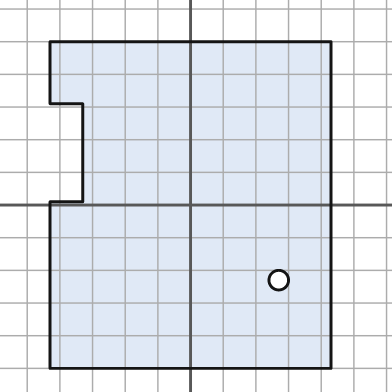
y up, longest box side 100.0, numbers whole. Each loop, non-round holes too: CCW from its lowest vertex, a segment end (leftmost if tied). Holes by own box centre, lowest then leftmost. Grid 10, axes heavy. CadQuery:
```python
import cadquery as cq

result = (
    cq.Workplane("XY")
    .moveTo(-43.0, -50.0)
    .lineTo(43.0, -50.0)
    .lineTo(43.0, 50.0)
    .lineTo(-43.0, 50.0)
    .lineTo(-43.0, 31.0)
    .lineTo(-33.0, 31.0)
    .lineTo(-33.0, 1.0)
    .lineTo(-43.0, 1.0)
    .close()
    .moveTo(27.0, -23.0)
    .circle(3.0)
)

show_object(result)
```